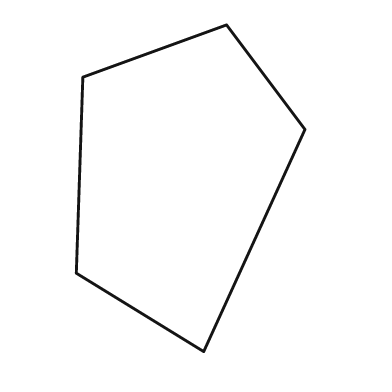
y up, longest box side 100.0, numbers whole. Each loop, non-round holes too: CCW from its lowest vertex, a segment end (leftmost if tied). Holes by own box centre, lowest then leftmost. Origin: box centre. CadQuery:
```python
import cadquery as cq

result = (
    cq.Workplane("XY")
    .moveTo(4.0, -50.0)
    .lineTo(35.0, 18.0)
    .lineTo(11.0, 50.0)
    .lineTo(-33.0, 34.0)
    .lineTo(-35.0, -26.0)
    .close()
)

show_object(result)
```